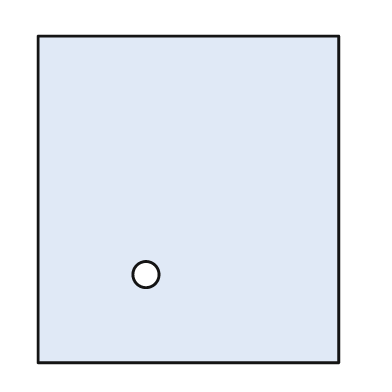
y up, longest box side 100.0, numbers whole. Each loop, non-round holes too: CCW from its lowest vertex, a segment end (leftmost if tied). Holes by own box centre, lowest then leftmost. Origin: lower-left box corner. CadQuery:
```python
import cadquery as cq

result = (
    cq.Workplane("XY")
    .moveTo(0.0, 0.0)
    .lineTo(92.0, 0.0)
    .lineTo(92.0, 100.0)
    .lineTo(0.0, 100.0)
    .close()
    .moveTo(33.0, 27.0)
    .circle(4.0)
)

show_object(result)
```